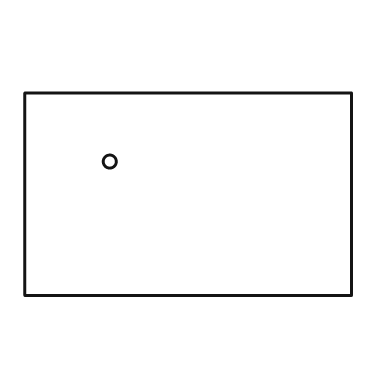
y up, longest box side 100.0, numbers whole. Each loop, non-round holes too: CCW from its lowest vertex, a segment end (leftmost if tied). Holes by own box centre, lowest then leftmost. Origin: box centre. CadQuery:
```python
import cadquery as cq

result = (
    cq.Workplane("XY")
    .moveTo(-50.0, -31.0)
    .lineTo(50.0, -31.0)
    .lineTo(50.0, 31.0)
    .lineTo(-50.0, 31.0)
    .close()
    .moveTo(-24.0, 10.0)
    .circle(2.0)
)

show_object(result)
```